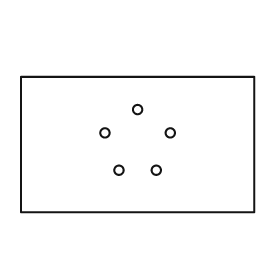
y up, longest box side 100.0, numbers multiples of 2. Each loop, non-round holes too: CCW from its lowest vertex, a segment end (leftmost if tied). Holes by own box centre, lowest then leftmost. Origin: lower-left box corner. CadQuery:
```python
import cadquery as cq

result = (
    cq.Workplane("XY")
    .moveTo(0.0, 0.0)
    .lineTo(100.0, 0.0)
    .lineTo(100.0, 58.0)
    .lineTo(0.0, 58.0)
    .close()
    .moveTo(42.0, 18.0)
    .circle(2.0)
    .moveTo(58.0, 18.0)
    .circle(2.0)
    .moveTo(36.0, 34.0)
    .circle(2.0)
    .moveTo(64.0, 34.0)
    .circle(2.0)
    .moveTo(50.0, 44.0)
    .circle(2.0)
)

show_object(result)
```